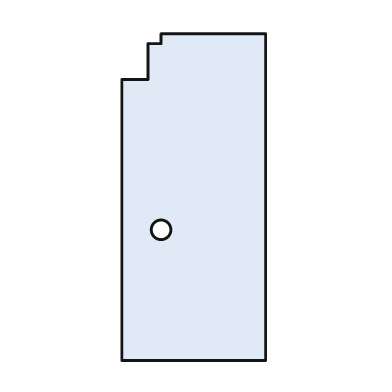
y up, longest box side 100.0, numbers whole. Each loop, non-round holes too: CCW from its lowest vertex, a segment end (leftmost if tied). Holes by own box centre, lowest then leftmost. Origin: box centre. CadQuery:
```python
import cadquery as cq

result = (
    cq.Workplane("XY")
    .moveTo(-22.0, -50.0)
    .lineTo(22.0, -50.0)
    .lineTo(22.0, 50.0)
    .lineTo(-10.0, 50.0)
    .lineTo(-10.0, 47.0)
    .lineTo(-14.0, 47.0)
    .lineTo(-14.0, 36.0)
    .lineTo(-22.0, 36.0)
    .close()
    .moveTo(-10.0, -10.0)
    .circle(3.0)
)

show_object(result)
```